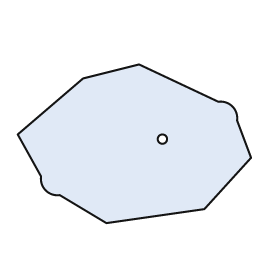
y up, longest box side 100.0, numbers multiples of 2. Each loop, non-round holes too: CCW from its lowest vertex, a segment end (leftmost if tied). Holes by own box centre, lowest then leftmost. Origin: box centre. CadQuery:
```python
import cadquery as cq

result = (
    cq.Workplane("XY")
    .moveTo(-12.0, -34.0)
    .lineTo(30.0, -28.0)
    .lineTo(50.0, -6.0)
    .lineTo(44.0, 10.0)
    .threePointArc((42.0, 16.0), (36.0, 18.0))
    .lineTo(2.0, 34.0)
    .lineTo(-22.0, 28.0)
    .lineTo(-50.0, 4.0)
    .lineTo(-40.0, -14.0)
    .threePointArc((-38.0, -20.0), (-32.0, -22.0))
    .close()
    .moveTo(12.0, 2.0)
    .circle(2.0)
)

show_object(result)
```